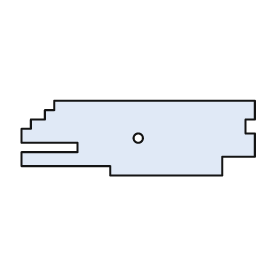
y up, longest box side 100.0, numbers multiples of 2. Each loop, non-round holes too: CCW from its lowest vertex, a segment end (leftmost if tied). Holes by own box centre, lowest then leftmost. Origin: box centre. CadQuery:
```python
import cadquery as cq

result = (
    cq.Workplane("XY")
    .moveTo(-12.0, -16.0)
    .lineTo(36.0, -16.0)
    .lineTo(36.0, -8.0)
    .lineTo(50.0, -8.0)
    .lineTo(50.0, 2.0)
    .lineTo(46.0, 2.0)
    .lineTo(46.0, 8.0)
    .lineTo(50.0, 8.0)
    .lineTo(50.0, 16.0)
    .lineTo(-36.0, 16.0)
    .lineTo(-36.0, 12.0)
    .lineTo(-40.0, 12.0)
    .lineTo(-40.0, 8.0)
    .lineTo(-46.0, 8.0)
    .lineTo(-46.0, 4.0)
    .lineTo(-50.0, 4.0)
    .lineTo(-50.0, -2.0)
    .lineTo(-26.0, -2.0)
    .lineTo(-26.0, -6.0)
    .lineTo(-50.0, -6.0)
    .lineTo(-50.0, -12.0)
    .lineTo(-12.0, -12.0)
    .close()
    .moveTo(0.0, 0.0)
    .circle(2.0)
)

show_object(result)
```